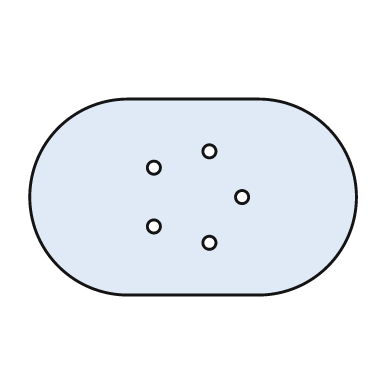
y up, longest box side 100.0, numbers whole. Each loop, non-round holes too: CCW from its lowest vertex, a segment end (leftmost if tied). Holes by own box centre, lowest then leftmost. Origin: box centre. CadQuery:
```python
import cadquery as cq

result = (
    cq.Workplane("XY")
    .moveTo(-20.0, -30.0)
    .lineTo(20.0, -30.0)
    .threePointArc((50.0, 0.0), (20.0, 30.0))
    .lineTo(-20.0, 30.0)
    .threePointArc((-50.0, 0.0), (-20.0, -30.0))
    .close()
    .moveTo(5.0, -14.0)
    .circle(2.0)
    .moveTo(-12.0, -9.0)
    .circle(2.0)
    .moveTo(15.0, 0.0)
    .circle(2.0)
    .moveTo(-12.0, 9.0)
    .circle(2.0)
    .moveTo(5.0, 14.0)
    .circle(2.0)
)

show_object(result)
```